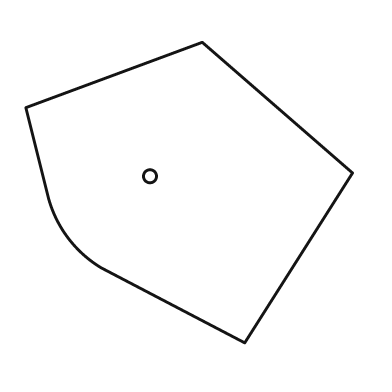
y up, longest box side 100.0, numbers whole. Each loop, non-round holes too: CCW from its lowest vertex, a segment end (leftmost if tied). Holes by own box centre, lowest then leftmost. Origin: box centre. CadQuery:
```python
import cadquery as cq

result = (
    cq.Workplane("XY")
    .moveTo(17.0, -46.0)
    .lineTo(50.0, 6.0)
    .lineTo(4.0, 46.0)
    .lineTo(-50.0, 26.0)
    .lineTo(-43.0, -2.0)
    .threePointArc((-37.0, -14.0), (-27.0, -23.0))
    .close()
    .moveTo(-12.0, 5.0)
    .circle(2.0)
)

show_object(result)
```